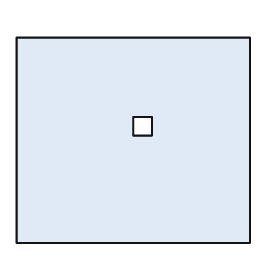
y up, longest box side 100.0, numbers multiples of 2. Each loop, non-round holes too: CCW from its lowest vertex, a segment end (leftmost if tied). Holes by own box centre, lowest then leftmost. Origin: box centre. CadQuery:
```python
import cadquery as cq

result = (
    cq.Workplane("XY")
    .moveTo(-50.0, -44.0)
    .lineTo(50.0, -44.0)
    .lineTo(50.0, 44.0)
    .lineTo(-50.0, 44.0)
    .close()
    .moveTo(0.0, 2.0)
    .lineTo(8.0, 2.0)
    .lineTo(8.0, 10.0)
    .lineTo(0.0, 10.0)
    .close()
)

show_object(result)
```